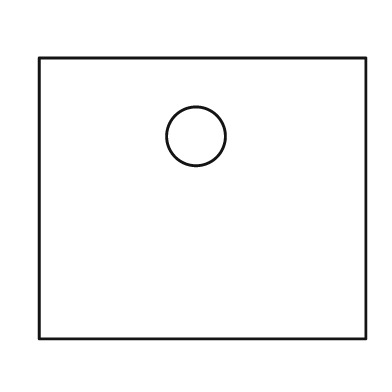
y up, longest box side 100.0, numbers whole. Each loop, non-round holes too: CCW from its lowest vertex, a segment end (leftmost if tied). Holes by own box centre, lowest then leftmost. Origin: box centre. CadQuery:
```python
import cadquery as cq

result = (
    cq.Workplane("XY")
    .moveTo(-50.0, -43.0)
    .lineTo(50.0, -43.0)
    .lineTo(50.0, 43.0)
    .lineTo(-50.0, 43.0)
    .close()
    .moveTo(-2.0, 19.0)
    .circle(9.0)
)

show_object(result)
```